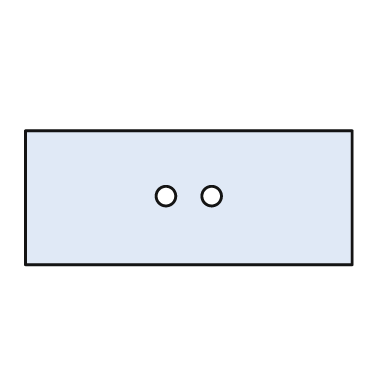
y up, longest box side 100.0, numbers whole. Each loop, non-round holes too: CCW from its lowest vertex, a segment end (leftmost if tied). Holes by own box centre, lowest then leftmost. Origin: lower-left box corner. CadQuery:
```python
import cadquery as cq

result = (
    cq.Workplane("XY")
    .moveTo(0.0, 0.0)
    .lineTo(100.0, 0.0)
    .lineTo(100.0, 41.0)
    .lineTo(0.0, 41.0)
    .close()
    .moveTo(43.0, 21.0)
    .circle(3.0)
    .moveTo(57.0, 21.0)
    .circle(3.0)
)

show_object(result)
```